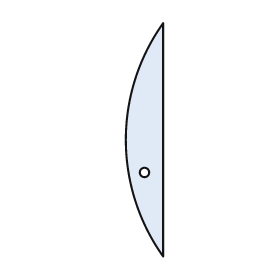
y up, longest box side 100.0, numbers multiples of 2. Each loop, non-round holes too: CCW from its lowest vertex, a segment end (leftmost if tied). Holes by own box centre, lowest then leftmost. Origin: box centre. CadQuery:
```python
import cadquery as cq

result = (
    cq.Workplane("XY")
    .moveTo(8.0, -50.0)
    .lineTo(8.0, 50.0)
    .threePointArc((-8.0, 0.0), (8.0, -50.0))
    .close()
    .moveTo(0.0, -14.0)
    .circle(2.0)
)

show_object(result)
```